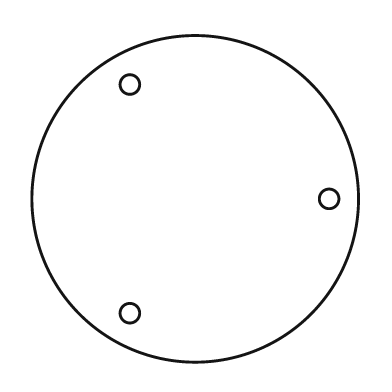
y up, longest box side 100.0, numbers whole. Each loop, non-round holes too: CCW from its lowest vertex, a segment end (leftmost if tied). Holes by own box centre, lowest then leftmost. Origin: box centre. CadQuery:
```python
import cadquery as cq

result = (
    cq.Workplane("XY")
    .moveTo(0.0, 0.0)
    .circle(50.0)
    .moveTo(-20.0, -35.0)
    .circle(3.0)
    .moveTo(41.0, 0.0)
    .circle(3.0)
    .moveTo(-20.0, 35.0)
    .circle(3.0)
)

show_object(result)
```